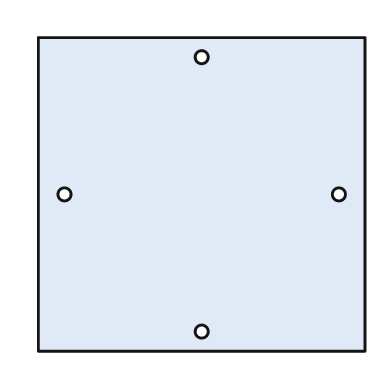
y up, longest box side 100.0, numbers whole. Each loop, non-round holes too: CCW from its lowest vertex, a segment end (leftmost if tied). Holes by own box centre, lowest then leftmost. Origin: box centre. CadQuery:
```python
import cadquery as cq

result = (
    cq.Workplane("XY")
    .moveTo(-50.0, -48.0)
    .lineTo(50.0, -48.0)
    .lineTo(50.0, 48.0)
    .lineTo(-50.0, 48.0)
    .close()
    .moveTo(0.0, -42.0)
    .circle(2.0)
    .moveTo(-42.0, 0.0)
    .circle(2.0)
    .moveTo(42.0, 0.0)
    .circle(2.0)
    .moveTo(0.0, 42.0)
    .circle(2.0)
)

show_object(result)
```